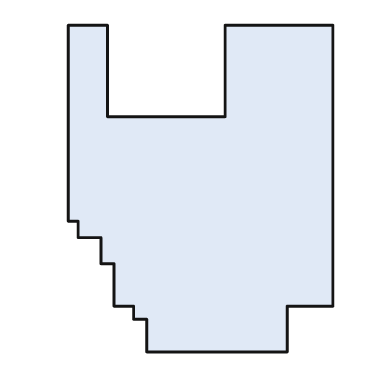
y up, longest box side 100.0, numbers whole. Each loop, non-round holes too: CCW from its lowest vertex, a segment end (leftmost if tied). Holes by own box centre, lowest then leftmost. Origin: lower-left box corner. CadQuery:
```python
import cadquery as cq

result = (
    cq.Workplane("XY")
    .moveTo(24.0, 0.0)
    .lineTo(67.0, 0.0)
    .lineTo(67.0, 14.0)
    .lineTo(81.0, 14.0)
    .lineTo(81.0, 100.0)
    .lineTo(48.0, 100.0)
    .lineTo(48.0, 72.0)
    .lineTo(12.0, 72.0)
    .lineTo(12.0, 100.0)
    .lineTo(0.0, 100.0)
    .lineTo(0.0, 40.0)
    .lineTo(3.0, 40.0)
    .lineTo(3.0, 35.0)
    .lineTo(10.0, 35.0)
    .lineTo(10.0, 27.0)
    .lineTo(14.0, 27.0)
    .lineTo(14.0, 14.0)
    .lineTo(20.0, 14.0)
    .lineTo(20.0, 10.0)
    .lineTo(24.0, 10.0)
    .close()
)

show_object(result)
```